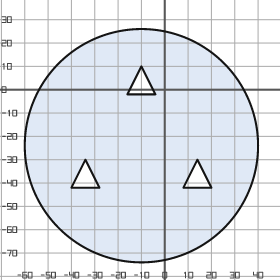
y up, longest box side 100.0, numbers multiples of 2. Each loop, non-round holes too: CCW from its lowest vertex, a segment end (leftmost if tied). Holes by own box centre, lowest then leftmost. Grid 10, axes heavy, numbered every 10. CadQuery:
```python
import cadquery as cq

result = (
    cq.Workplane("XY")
    .moveTo(-10.0, -24.0)
    .circle(50.0)
    .moveTo(-40.0, -42.0)
    .lineTo(-28.0, -42.0)
    .lineTo(-34.0, -30.0)
    .close()
    .moveTo(8.0, -42.0)
    .lineTo(20.0, -42.0)
    .lineTo(14.0, -30.0)
    .close()
    .moveTo(-16.0, -2.0)
    .lineTo(-4.0, -2.0)
    .lineTo(-10.0, 10.0)
    .close()
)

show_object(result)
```